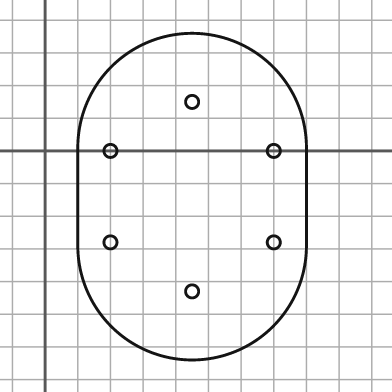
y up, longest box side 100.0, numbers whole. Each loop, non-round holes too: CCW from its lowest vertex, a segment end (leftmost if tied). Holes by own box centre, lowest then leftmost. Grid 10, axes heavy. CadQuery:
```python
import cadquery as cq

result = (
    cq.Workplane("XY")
    .moveTo(10.0, -29.0)
    .threePointArc((45.0, -64.0), (80.0, -29.0))
    .lineTo(80.0, 1.0)
    .threePointArc((45.0, 36.0), (10.0, 1.0))
    .close()
    .moveTo(45.0, -43.0)
    .circle(2.0)
    .moveTo(20.0, -28.0)
    .circle(2.0)
    .moveTo(70.0, -28.0)
    .circle(2.0)
    .moveTo(20.0, 0.0)
    .circle(2.0)
    .moveTo(70.0, 0.0)
    .circle(2.0)
    .moveTo(45.0, 15.0)
    .circle(2.0)
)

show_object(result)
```